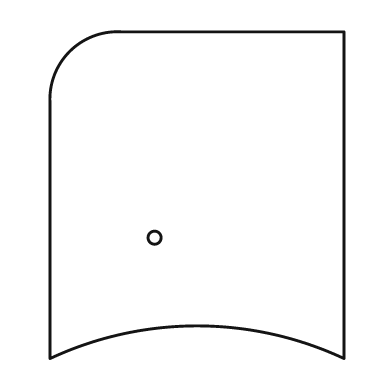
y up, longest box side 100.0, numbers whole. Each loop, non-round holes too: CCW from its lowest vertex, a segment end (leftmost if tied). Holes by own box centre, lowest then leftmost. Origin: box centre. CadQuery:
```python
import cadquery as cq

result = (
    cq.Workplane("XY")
    .moveTo(-45.0, -50.0)
    .threePointArc((0.0, -40.0), (45.0, -50.0))
    .lineTo(45.0, 50.0)
    .lineTo(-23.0, 50.0)
    .threePointArc((-39.0, 44.0), (-45.0, 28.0))
    .close()
    .moveTo(-13.0, -13.0)
    .circle(2.0)
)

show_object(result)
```